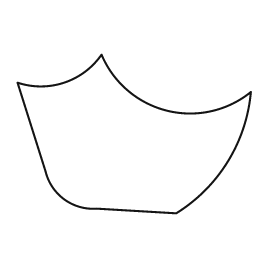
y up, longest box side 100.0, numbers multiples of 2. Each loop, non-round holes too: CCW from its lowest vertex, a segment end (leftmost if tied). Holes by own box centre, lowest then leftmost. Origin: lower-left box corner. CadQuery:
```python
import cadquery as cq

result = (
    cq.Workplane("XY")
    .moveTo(68.0, 0.0)
    .threePointArc((90.0, 22.0), (100.0, 52.0))
    .threePointArc((64.0, 44.0), (36.0, 68.0))
    .threePointArc((20.0, 56.0), (0.0, 56.0))
    .lineTo(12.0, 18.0)
    .threePointArc((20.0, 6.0), (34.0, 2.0))
    .close()
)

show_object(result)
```